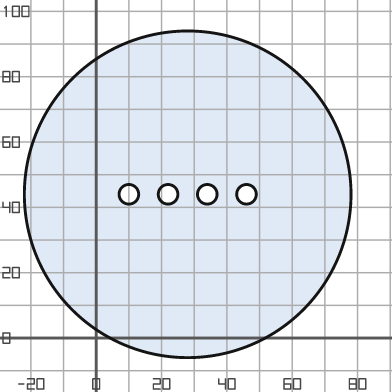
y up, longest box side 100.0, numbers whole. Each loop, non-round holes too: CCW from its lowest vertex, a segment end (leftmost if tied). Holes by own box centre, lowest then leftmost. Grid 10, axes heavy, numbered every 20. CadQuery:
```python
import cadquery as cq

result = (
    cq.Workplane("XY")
    .moveTo(28.0, 44.0)
    .circle(50.0)
    .moveTo(10.0, 44.0)
    .circle(3.0)
    .moveTo(22.0, 44.0)
    .circle(3.0)
    .moveTo(34.0, 44.0)
    .circle(3.0)
    .moveTo(46.0, 44.0)
    .circle(3.0)
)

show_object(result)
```